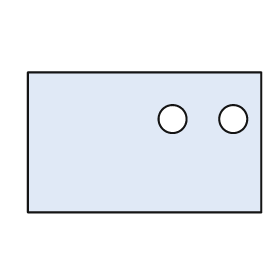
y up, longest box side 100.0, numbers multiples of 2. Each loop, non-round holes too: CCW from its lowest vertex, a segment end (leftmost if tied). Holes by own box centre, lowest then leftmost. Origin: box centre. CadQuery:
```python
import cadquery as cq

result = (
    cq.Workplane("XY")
    .moveTo(-50.0, -30.0)
    .lineTo(50.0, -30.0)
    .lineTo(50.0, 30.0)
    .lineTo(-50.0, 30.0)
    .close()
    .moveTo(12.0, 10.0)
    .circle(6.0)
    .moveTo(38.0, 10.0)
    .circle(6.0)
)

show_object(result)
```